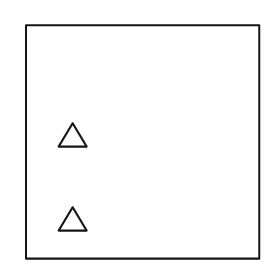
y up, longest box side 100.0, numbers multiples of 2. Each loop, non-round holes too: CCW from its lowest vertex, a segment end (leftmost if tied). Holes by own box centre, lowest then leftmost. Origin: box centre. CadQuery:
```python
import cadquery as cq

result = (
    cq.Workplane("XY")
    .moveTo(-50.0, -50.0)
    .lineTo(50.0, -50.0)
    .lineTo(50.0, 50.0)
    .lineTo(-50.0, 50.0)
    .close()
    .moveTo(-36.0, -38.0)
    .lineTo(-24.0, -38.0)
    .lineTo(-30.0, -28.0)
    .close()
    .moveTo(-36.0, -2.0)
    .lineTo(-24.0, -2.0)
    .lineTo(-30.0, 8.0)
    .close()
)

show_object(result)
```